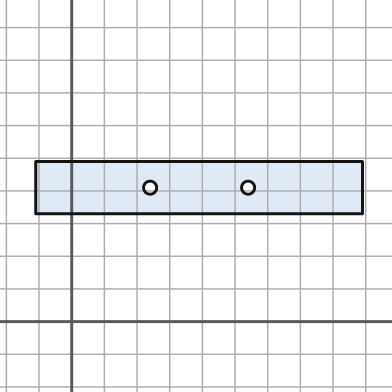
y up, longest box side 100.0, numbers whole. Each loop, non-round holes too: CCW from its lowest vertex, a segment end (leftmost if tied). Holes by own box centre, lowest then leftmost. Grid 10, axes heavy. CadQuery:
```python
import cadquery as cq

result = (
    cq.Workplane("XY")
    .moveTo(-11.0, 33.0)
    .lineTo(89.0, 33.0)
    .lineTo(89.0, 49.0)
    .lineTo(-11.0, 49.0)
    .close()
    .moveTo(24.0, 41.0)
    .circle(2.0)
    .moveTo(54.0, 41.0)
    .circle(2.0)
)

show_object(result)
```